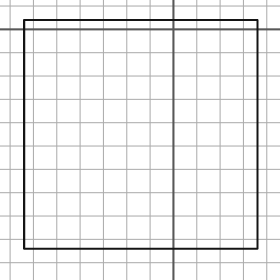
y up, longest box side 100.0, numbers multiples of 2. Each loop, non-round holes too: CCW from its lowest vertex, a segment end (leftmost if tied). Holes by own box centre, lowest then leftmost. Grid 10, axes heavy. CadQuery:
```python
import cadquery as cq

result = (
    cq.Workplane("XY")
    .moveTo(-64.0, -94.0)
    .lineTo(36.0, -94.0)
    .lineTo(36.0, 4.0)
    .lineTo(-64.0, 4.0)
    .close()
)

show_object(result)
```